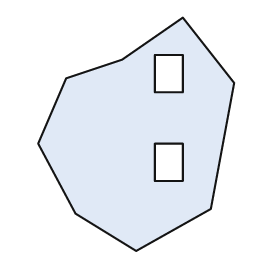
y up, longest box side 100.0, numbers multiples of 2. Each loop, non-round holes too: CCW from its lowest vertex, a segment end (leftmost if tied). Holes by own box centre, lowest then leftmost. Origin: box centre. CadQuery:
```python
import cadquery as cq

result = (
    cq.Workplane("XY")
    .moveTo(0.0, -50.0)
    .lineTo(32.0, -32.0)
    .lineTo(42.0, 22.0)
    .lineTo(20.0, 50.0)
    .lineTo(-6.0, 32.0)
    .lineTo(-30.0, 24.0)
    .lineTo(-42.0, -4.0)
    .lineTo(-26.0, -34.0)
    .close()
    .moveTo(8.0, -20.0)
    .lineTo(20.0, -20.0)
    .lineTo(20.0, -4.0)
    .lineTo(8.0, -4.0)
    .close()
    .moveTo(8.0, 18.0)
    .lineTo(20.0, 18.0)
    .lineTo(20.0, 34.0)
    .lineTo(8.0, 34.0)
    .close()
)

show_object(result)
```